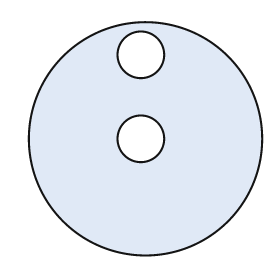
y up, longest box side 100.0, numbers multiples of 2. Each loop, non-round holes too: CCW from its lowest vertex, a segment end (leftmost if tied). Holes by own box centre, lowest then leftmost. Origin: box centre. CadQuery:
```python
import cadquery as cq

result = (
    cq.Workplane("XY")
    .moveTo(0.0, 0.0)
    .circle(50.0)
    .moveTo(-2.0, 0.0)
    .circle(10.0)
    .moveTo(-2.0, 36.0)
    .circle(10.0)
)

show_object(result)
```